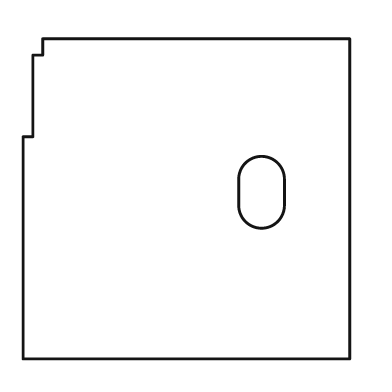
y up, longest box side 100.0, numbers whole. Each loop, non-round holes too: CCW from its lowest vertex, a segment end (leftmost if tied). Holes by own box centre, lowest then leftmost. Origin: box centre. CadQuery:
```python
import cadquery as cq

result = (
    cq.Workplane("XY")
    .moveTo(-50.0, -49.0)
    .lineTo(50.0, -49.0)
    .lineTo(50.0, 49.0)
    .lineTo(-44.0, 49.0)
    .lineTo(-44.0, 44.0)
    .lineTo(-47.0, 44.0)
    .lineTo(-47.0, 19.0)
    .lineTo(-50.0, 19.0)
    .close()
    .moveTo(16.0, -2.0)
    .threePointArc((23.0, -9.0), (30.0, -2.0))
    .lineTo(30.0, 6.0)
    .threePointArc((23.0, 13.0), (16.0, 6.0))
    .close()
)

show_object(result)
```